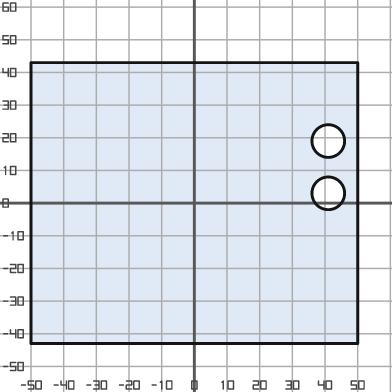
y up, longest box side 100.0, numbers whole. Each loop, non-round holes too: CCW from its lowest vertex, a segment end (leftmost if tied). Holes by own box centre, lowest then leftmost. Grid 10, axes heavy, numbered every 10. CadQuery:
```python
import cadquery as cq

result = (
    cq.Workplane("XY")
    .moveTo(-50.0, -43.0)
    .lineTo(50.0, -43.0)
    .lineTo(50.0, 43.0)
    .lineTo(-50.0, 43.0)
    .close()
    .moveTo(41.0, 3.0)
    .circle(5.0)
    .moveTo(41.0, 19.0)
    .circle(5.0)
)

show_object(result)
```